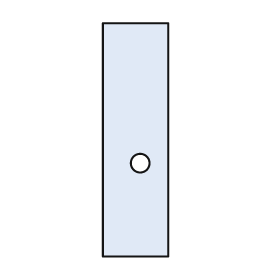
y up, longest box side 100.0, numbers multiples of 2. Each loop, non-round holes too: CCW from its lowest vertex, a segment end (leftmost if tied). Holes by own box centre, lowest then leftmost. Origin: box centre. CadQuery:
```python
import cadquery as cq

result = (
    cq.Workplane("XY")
    .moveTo(-14.0, -50.0)
    .lineTo(14.0, -50.0)
    .lineTo(14.0, 50.0)
    .lineTo(-14.0, 50.0)
    .close()
    .moveTo(2.0, -10.0)
    .circle(4.0)
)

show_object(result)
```